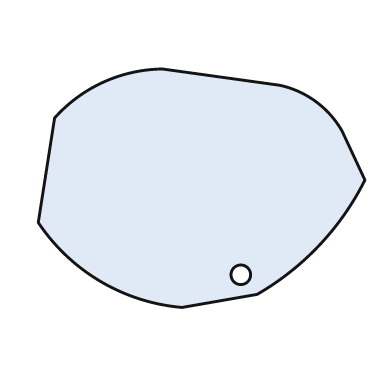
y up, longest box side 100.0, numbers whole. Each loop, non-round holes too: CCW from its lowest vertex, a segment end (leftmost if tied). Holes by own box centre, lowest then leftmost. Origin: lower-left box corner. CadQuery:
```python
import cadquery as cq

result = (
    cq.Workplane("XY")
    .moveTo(44.0, 0.0)
    .lineTo(67.0, 4.0)
    .threePointArc((86.0, 19.0), (100.0, 39.0))
    .lineTo(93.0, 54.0)
    .threePointArc((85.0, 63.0), (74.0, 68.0))
    .lineTo(38.0, 73.0)
    .threePointArc((20.0, 69.0), (5.0, 58.0))
    .lineTo(0.0, 26.0)
    .threePointArc((19.0, 8.0), (44.0, 0.0))
    .close()
    .moveTo(62.0, 10.0)
    .circle(3.0)
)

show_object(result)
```